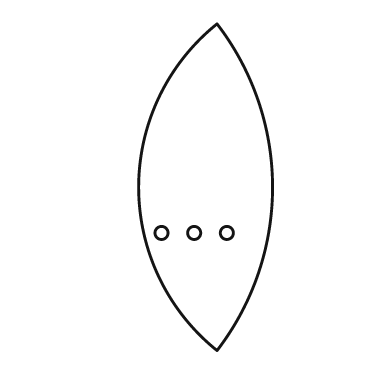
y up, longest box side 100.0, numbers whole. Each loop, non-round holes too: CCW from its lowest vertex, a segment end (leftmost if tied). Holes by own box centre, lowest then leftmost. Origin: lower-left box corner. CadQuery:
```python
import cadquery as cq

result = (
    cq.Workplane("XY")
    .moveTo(24.0, 0.0)
    .threePointArc((41.0, 50.0), (24.0, 100.0))
    .threePointArc((0.0, 50.0), (24.0, 0.0))
    .close()
    .moveTo(7.0, 36.0)
    .circle(2.0)
    .moveTo(17.0, 36.0)
    .circle(2.0)
    .moveTo(27.0, 36.0)
    .circle(2.0)
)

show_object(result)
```